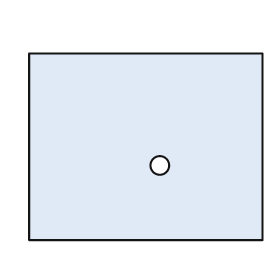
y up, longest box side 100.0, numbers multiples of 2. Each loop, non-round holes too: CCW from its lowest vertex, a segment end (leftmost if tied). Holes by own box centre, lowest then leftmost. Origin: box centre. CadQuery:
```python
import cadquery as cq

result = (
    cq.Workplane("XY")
    .moveTo(-50.0, -40.0)
    .lineTo(50.0, -40.0)
    .lineTo(50.0, 40.0)
    .lineTo(-50.0, 40.0)
    .close()
    .moveTo(6.0, -8.0)
    .circle(4.0)
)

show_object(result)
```